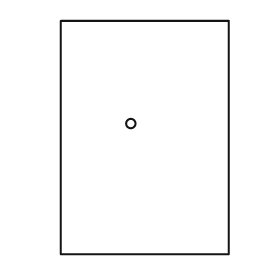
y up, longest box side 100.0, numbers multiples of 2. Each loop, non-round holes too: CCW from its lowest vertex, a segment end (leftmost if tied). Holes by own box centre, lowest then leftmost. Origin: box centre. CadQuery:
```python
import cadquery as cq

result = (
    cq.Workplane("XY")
    .moveTo(-36.0, -50.0)
    .lineTo(36.0, -50.0)
    .lineTo(36.0, 50.0)
    .lineTo(-36.0, 50.0)
    .close()
    .moveTo(-6.0, 6.0)
    .circle(2.0)
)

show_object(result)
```